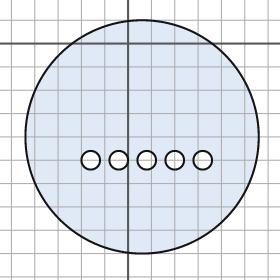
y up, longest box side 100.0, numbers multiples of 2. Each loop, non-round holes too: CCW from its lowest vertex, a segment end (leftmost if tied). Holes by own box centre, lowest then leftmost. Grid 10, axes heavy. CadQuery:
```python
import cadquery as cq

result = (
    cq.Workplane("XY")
    .moveTo(6.0, -40.0)
    .circle(50.0)
    .moveTo(-16.0, -50.0)
    .circle(4.0)
    .moveTo(-4.0, -50.0)
    .circle(4.0)
    .moveTo(8.0, -50.0)
    .circle(4.0)
    .moveTo(20.0, -50.0)
    .circle(4.0)
    .moveTo(32.0, -50.0)
    .circle(4.0)
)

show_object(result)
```